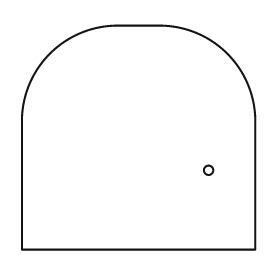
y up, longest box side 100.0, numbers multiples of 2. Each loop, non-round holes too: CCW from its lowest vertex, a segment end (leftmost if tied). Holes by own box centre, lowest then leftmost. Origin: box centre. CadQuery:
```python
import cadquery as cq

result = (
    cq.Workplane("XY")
    .moveTo(-50.0, -48.0)
    .lineTo(50.0, -48.0)
    .lineTo(50.0, 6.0)
    .threePointArc((38.0, 36.0), (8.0, 48.0))
    .lineTo(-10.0, 48.0)
    .threePointArc((-38.0, 36.0), (-50.0, 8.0))
    .close()
    .moveTo(30.0, -14.0)
    .circle(2.0)
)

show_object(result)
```